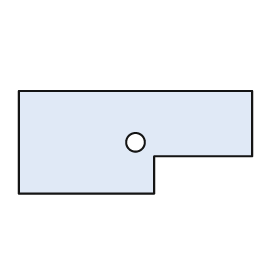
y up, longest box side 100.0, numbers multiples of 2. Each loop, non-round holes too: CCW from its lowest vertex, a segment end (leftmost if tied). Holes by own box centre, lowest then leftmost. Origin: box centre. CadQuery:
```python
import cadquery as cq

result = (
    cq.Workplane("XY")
    .moveTo(-50.0, -22.0)
    .lineTo(8.0, -22.0)
    .lineTo(8.0, -6.0)
    .lineTo(50.0, -6.0)
    .lineTo(50.0, 22.0)
    .lineTo(-50.0, 22.0)
    .close()
    .moveTo(0.0, 0.0)
    .circle(4.0)
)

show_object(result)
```